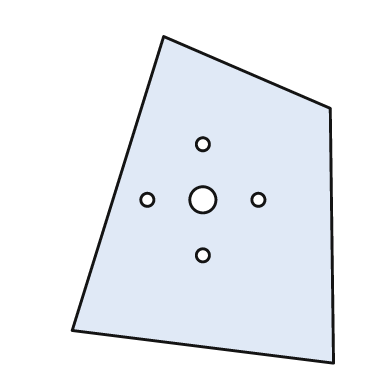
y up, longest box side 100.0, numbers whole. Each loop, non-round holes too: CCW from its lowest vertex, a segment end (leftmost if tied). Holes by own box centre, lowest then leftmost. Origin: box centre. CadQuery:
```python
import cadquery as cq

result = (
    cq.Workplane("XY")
    .moveTo(40.0, -50.0)
    .lineTo(39.0, 28.0)
    .lineTo(-12.0, 50.0)
    .lineTo(-40.0, -40.0)
    .close()
    .moveTo(0.0, -17.0)
    .circle(2.0)
    .moveTo(-17.0, 0.0)
    .circle(2.0)
    .moveTo(0.0, 0.0)
    .circle(4.0)
    .moveTo(17.0, 0.0)
    .circle(2.0)
    .moveTo(0.0, 17.0)
    .circle(2.0)
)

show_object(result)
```